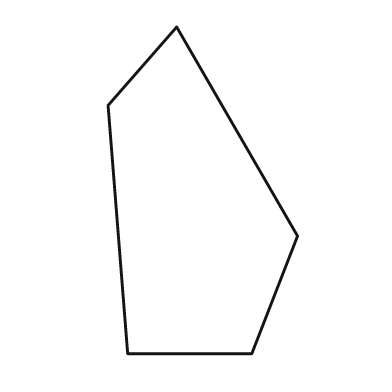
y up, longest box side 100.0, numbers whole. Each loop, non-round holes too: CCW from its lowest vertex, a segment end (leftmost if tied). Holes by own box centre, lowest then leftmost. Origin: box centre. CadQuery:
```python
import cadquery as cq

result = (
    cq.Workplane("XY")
    .moveTo(-23.0, -50.0)
    .lineTo(15.0, -50.0)
    .lineTo(29.0, -14.0)
    .lineTo(-8.0, 50.0)
    .lineTo(-29.0, 26.0)
    .close()
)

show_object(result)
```